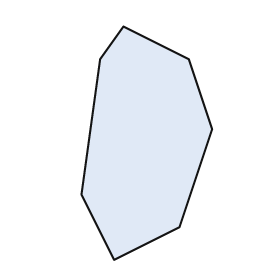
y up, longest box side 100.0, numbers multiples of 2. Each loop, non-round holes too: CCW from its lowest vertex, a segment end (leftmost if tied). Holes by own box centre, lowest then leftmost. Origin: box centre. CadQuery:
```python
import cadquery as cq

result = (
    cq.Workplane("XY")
    .moveTo(-14.0, -50.0)
    .lineTo(14.0, -36.0)
    .lineTo(28.0, 6.0)
    .lineTo(18.0, 36.0)
    .lineTo(-10.0, 50.0)
    .lineTo(-20.0, 36.0)
    .lineTo(-28.0, -22.0)
    .close()
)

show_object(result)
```